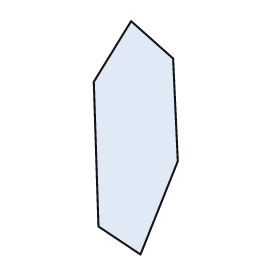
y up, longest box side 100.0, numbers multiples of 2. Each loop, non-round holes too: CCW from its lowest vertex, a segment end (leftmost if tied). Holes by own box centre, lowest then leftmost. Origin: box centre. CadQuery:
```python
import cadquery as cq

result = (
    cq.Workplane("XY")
    .moveTo(2.0, -50.0)
    .lineTo(18.0, -10.0)
    .lineTo(16.0, 34.0)
    .lineTo(-2.0, 50.0)
    .lineTo(-18.0, 24.0)
    .lineTo(-16.0, -38.0)
    .close()
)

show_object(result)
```